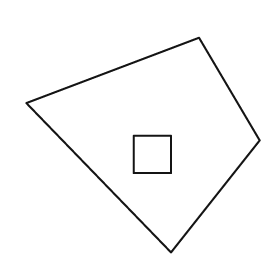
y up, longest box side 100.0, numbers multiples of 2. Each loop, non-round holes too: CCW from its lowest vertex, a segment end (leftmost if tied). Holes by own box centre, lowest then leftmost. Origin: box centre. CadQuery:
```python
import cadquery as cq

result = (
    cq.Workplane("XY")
    .moveTo(12.0, -46.0)
    .lineTo(50.0, 2.0)
    .lineTo(24.0, 46.0)
    .lineTo(-50.0, 18.0)
    .close()
    .moveTo(-4.0, -12.0)
    .lineTo(12.0, -12.0)
    .lineTo(12.0, 4.0)
    .lineTo(-4.0, 4.0)
    .close()
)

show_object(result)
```